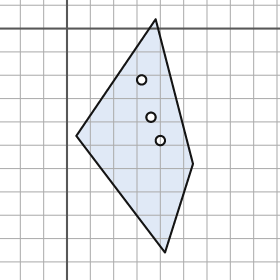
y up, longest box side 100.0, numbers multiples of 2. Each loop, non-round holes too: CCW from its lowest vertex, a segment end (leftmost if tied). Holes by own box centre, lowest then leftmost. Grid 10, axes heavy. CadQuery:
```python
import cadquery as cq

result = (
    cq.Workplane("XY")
    .moveTo(42.0, -96.0)
    .lineTo(54.0, -58.0)
    .lineTo(38.0, 4.0)
    .lineTo(4.0, -46.0)
    .close()
    .moveTo(40.0, -48.0)
    .circle(2.0)
    .moveTo(36.0, -38.0)
    .circle(2.0)
    .moveTo(32.0, -22.0)
    .circle(2.0)
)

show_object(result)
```